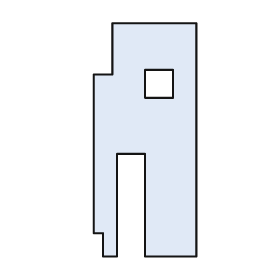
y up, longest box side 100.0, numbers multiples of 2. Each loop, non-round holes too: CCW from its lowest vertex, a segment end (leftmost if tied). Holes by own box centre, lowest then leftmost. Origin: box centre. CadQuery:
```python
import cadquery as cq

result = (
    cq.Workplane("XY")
    .moveTo(-18.0, -50.0)
    .lineTo(-12.0, -50.0)
    .lineTo(-12.0, -6.0)
    .lineTo(0.0, -6.0)
    .lineTo(0.0, -50.0)
    .lineTo(22.0, -50.0)
    .lineTo(22.0, 50.0)
    .lineTo(-14.0, 50.0)
    .lineTo(-14.0, 28.0)
    .lineTo(-22.0, 28.0)
    .lineTo(-22.0, -40.0)
    .lineTo(-18.0, -40.0)
    .close()
    .moveTo(0.0, 18.0)
    .lineTo(12.0, 18.0)
    .lineTo(12.0, 30.0)
    .lineTo(0.0, 30.0)
    .close()
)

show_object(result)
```